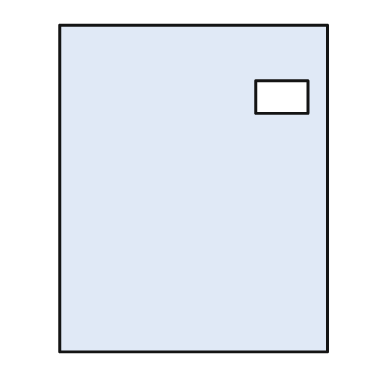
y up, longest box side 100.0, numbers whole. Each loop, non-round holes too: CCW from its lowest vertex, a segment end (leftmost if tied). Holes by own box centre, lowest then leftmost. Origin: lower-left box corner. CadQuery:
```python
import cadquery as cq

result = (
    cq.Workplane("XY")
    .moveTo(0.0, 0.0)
    .lineTo(82.0, 0.0)
    .lineTo(82.0, 100.0)
    .lineTo(0.0, 100.0)
    .close()
    .moveTo(60.0, 73.0)
    .lineTo(76.0, 73.0)
    .lineTo(76.0, 83.0)
    .lineTo(60.0, 83.0)
    .close()
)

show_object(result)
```